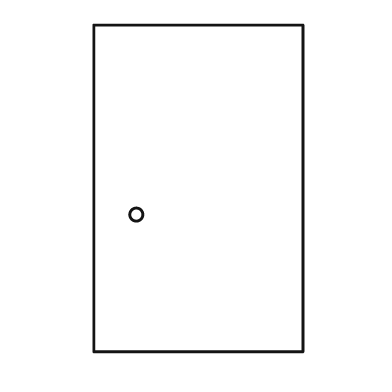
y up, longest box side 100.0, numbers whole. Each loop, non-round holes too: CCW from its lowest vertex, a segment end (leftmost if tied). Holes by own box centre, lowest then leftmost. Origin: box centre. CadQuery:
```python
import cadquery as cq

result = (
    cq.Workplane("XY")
    .moveTo(-32.0, -50.0)
    .lineTo(32.0, -50.0)
    .lineTo(32.0, 50.0)
    .lineTo(-32.0, 50.0)
    .close()
    .moveTo(-19.0, -8.0)
    .circle(2.0)
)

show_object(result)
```